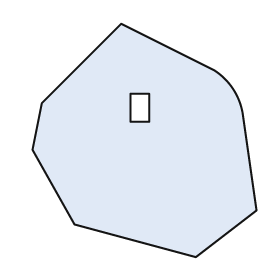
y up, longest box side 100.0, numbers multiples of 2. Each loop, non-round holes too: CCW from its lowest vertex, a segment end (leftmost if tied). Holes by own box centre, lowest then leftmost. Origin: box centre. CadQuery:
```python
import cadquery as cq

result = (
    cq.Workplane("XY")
    .moveTo(22.0, -50.0)
    .lineTo(48.0, -30.0)
    .lineTo(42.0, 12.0)
    .threePointArc((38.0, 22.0), (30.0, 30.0))
    .lineTo(-10.0, 50.0)
    .lineTo(-44.0, 16.0)
    .lineTo(-48.0, -4.0)
    .lineTo(-30.0, -36.0)
    .close()
    .moveTo(-6.0, 8.0)
    .lineTo(2.0, 8.0)
    .lineTo(2.0, 20.0)
    .lineTo(-6.0, 20.0)
    .close()
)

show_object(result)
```